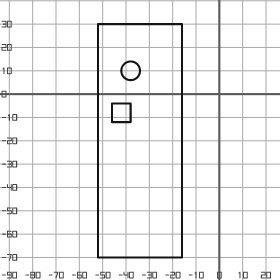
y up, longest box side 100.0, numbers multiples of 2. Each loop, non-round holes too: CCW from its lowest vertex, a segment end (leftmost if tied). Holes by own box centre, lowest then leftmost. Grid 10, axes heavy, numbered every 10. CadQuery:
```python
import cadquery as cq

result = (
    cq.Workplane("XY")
    .moveTo(-52.0, -70.0)
    .lineTo(-16.0, -70.0)
    .lineTo(-16.0, 30.0)
    .lineTo(-52.0, 30.0)
    .close()
    .moveTo(-46.0, -12.0)
    .lineTo(-38.0, -12.0)
    .lineTo(-38.0, -4.0)
    .lineTo(-46.0, -4.0)
    .close()
    .moveTo(-38.0, 10.0)
    .circle(4.0)
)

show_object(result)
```